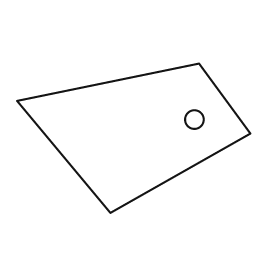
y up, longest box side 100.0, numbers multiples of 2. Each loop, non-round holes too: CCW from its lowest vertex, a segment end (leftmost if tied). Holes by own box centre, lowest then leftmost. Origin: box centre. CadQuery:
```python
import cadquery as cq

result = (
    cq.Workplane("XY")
    .moveTo(-10.0, -32.0)
    .lineTo(50.0, 2.0)
    .lineTo(28.0, 32.0)
    .lineTo(-50.0, 16.0)
    .close()
    .moveTo(26.0, 8.0)
    .circle(4.0)
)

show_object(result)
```